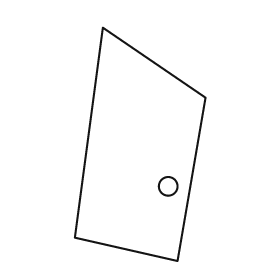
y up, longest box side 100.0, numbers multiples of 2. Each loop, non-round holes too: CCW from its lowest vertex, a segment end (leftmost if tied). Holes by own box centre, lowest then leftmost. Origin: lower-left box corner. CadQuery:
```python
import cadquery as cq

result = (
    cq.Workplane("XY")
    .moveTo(44.0, 0.0)
    .lineTo(56.0, 70.0)
    .lineTo(12.0, 100.0)
    .lineTo(0.0, 10.0)
    .close()
    .moveTo(40.0, 32.0)
    .circle(4.0)
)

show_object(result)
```